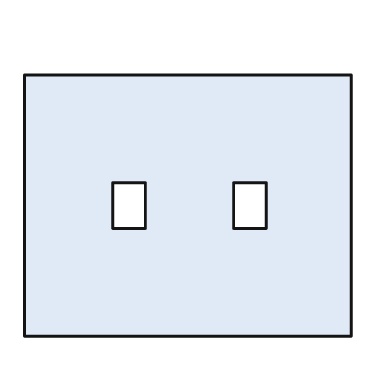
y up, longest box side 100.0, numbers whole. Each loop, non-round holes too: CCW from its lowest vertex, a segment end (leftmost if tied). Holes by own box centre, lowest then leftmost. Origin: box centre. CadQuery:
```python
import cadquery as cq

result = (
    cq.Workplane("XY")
    .moveTo(-50.0, -40.0)
    .lineTo(50.0, -40.0)
    .lineTo(50.0, 40.0)
    .lineTo(-50.0, 40.0)
    .close()
    .moveTo(-23.0, -7.0)
    .lineTo(-13.0, -7.0)
    .lineTo(-13.0, 7.0)
    .lineTo(-23.0, 7.0)
    .close()
    .moveTo(14.0, -7.0)
    .lineTo(24.0, -7.0)
    .lineTo(24.0, 7.0)
    .lineTo(14.0, 7.0)
    .close()
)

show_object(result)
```